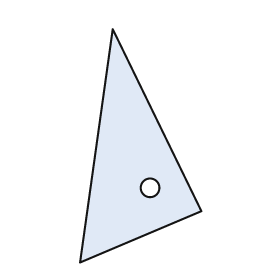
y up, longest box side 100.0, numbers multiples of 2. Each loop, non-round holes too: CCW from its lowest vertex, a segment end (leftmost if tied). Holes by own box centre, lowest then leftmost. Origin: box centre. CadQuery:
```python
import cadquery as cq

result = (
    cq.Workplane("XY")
    .moveTo(-26.0, -50.0)
    .lineTo(26.0, -28.0)
    .lineTo(-12.0, 50.0)
    .close()
    .moveTo(4.0, -18.0)
    .circle(4.0)
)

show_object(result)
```